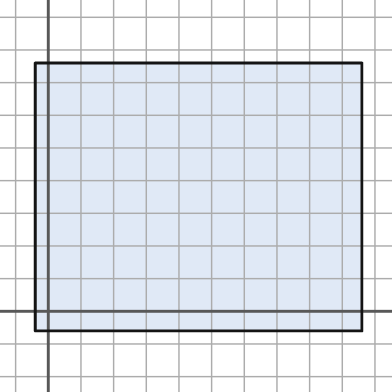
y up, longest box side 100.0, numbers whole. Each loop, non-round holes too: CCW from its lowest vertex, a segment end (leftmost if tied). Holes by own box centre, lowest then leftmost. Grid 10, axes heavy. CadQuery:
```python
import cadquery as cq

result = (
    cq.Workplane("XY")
    .moveTo(-4.0, -6.0)
    .lineTo(96.0, -6.0)
    .lineTo(96.0, 76.0)
    .lineTo(-4.0, 76.0)
    .close()
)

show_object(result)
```